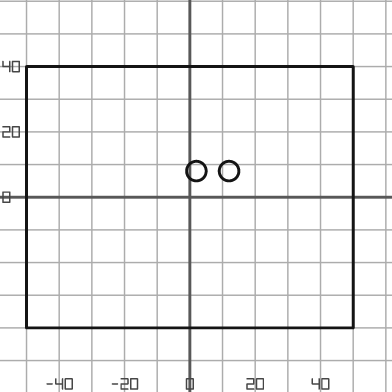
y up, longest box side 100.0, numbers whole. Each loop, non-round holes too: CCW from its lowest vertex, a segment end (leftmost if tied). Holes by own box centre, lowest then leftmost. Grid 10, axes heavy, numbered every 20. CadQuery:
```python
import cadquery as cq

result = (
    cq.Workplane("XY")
    .moveTo(-50.0, -40.0)
    .lineTo(50.0, -40.0)
    .lineTo(50.0, 40.0)
    .lineTo(-50.0, 40.0)
    .close()
    .moveTo(2.0, 8.0)
    .circle(3.0)
    .moveTo(12.0, 8.0)
    .circle(3.0)
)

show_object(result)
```